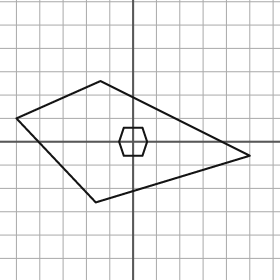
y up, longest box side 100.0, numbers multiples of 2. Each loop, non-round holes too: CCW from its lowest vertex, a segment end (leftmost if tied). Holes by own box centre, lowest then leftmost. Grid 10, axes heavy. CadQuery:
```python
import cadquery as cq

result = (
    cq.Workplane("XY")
    .moveTo(-16.0, -26.0)
    .lineTo(50.0, -6.0)
    .lineTo(-14.0, 26.0)
    .lineTo(-50.0, 10.0)
    .close()
    .moveTo(-4.0, -6.0)
    .lineTo(4.0, -6.0)
    .lineTo(6.0, 0.0)
    .lineTo(4.0, 6.0)
    .lineTo(-4.0, 6.0)
    .lineTo(-6.0, 0.0)
    .close()
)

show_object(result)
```